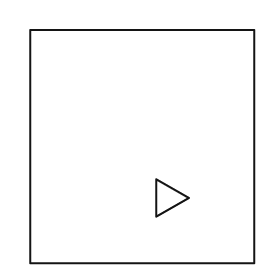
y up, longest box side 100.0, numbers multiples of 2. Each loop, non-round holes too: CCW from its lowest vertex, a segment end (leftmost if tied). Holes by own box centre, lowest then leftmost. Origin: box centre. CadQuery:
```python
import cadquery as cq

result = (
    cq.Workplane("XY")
    .moveTo(-48.0, -50.0)
    .lineTo(48.0, -50.0)
    .lineTo(48.0, 50.0)
    .lineTo(-48.0, 50.0)
    .close()
    .moveTo(6.0, -30.0)
    .lineTo(20.0, -22.0)
    .lineTo(6.0, -14.0)
    .close()
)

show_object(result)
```